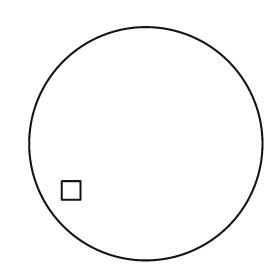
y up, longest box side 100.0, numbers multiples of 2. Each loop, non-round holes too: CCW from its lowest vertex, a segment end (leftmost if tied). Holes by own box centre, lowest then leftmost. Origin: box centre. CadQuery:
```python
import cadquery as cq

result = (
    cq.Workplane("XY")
    .moveTo(0.0, 0.0)
    .circle(50.0)
    .moveTo(-36.0, -24.0)
    .lineTo(-28.0, -24.0)
    .lineTo(-28.0, -16.0)
    .lineTo(-36.0, -16.0)
    .close()
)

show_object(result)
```